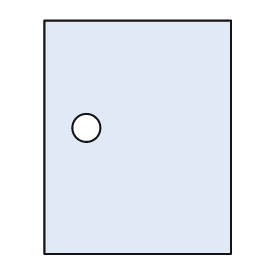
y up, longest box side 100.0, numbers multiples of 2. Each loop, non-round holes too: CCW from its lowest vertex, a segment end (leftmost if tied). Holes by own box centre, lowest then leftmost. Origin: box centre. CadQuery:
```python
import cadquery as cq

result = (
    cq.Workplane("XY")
    .moveTo(-40.0, -50.0)
    .lineTo(40.0, -50.0)
    .lineTo(40.0, 50.0)
    .lineTo(-40.0, 50.0)
    .close()
    .moveTo(-22.0, 4.0)
    .circle(6.0)
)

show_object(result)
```